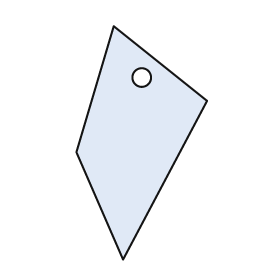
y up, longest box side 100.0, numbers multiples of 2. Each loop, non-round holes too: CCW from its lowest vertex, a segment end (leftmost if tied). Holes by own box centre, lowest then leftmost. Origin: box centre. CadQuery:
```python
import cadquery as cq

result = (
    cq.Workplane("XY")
    .moveTo(-8.0, -50.0)
    .lineTo(28.0, 18.0)
    .lineTo(-12.0, 50.0)
    .lineTo(-28.0, -4.0)
    .close()
    .moveTo(0.0, 28.0)
    .circle(4.0)
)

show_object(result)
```